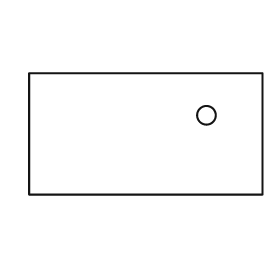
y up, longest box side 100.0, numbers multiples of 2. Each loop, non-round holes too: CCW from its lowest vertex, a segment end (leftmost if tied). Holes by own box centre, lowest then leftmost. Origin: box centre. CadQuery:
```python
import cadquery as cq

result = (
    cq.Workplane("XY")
    .moveTo(-50.0, -26.0)
    .lineTo(50.0, -26.0)
    .lineTo(50.0, 26.0)
    .lineTo(-50.0, 26.0)
    .close()
    .moveTo(26.0, 8.0)
    .circle(4.0)
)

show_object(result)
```